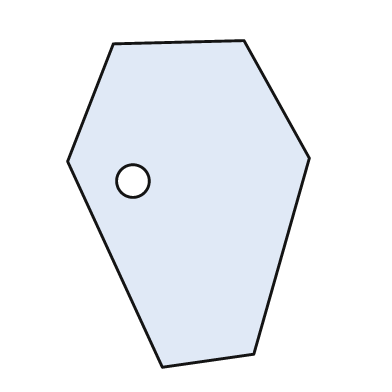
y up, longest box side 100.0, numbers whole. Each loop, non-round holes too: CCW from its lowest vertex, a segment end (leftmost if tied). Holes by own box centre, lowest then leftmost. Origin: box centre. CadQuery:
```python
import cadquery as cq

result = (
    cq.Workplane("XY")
    .moveTo(-8.0, -50.0)
    .lineTo(20.0, -46.0)
    .lineTo(37.0, 14.0)
    .lineTo(17.0, 50.0)
    .lineTo(-23.0, 49.0)
    .lineTo(-37.0, 13.0)
    .close()
    .moveTo(-17.0, 7.0)
    .circle(5.0)
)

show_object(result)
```